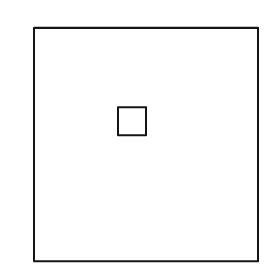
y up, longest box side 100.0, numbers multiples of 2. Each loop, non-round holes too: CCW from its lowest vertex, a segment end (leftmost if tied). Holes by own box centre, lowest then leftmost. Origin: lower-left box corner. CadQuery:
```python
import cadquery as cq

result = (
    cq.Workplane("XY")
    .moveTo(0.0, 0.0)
    .lineTo(96.0, 0.0)
    .lineTo(96.0, 100.0)
    .lineTo(0.0, 100.0)
    .close()
    .moveTo(36.0, 54.0)
    .lineTo(48.0, 54.0)
    .lineTo(48.0, 66.0)
    .lineTo(36.0, 66.0)
    .close()
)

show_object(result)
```